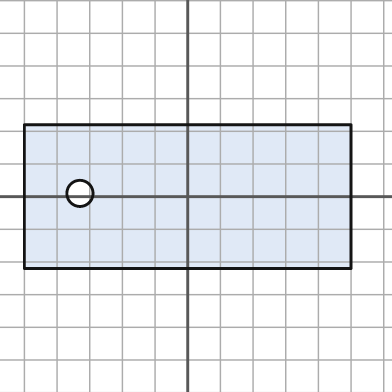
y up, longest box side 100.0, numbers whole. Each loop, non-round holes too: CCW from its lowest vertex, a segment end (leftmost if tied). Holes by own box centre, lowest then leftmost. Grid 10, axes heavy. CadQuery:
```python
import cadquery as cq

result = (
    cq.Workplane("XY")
    .moveTo(-50.0, -22.0)
    .lineTo(50.0, -22.0)
    .lineTo(50.0, 22.0)
    .lineTo(-50.0, 22.0)
    .close()
    .moveTo(-33.0, 1.0)
    .circle(4.0)
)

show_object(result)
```